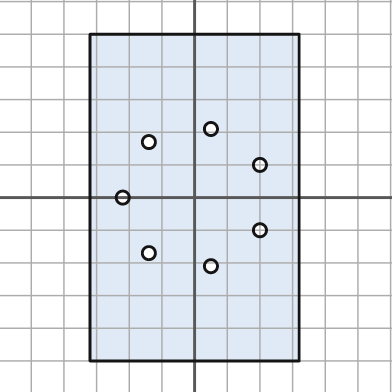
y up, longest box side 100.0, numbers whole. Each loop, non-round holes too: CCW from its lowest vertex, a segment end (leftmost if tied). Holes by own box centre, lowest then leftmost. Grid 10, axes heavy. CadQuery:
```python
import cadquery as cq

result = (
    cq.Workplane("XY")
    .moveTo(-32.0, -50.0)
    .lineTo(32.0, -50.0)
    .lineTo(32.0, 50.0)
    .lineTo(-32.0, 50.0)
    .close()
    .moveTo(5.0, -21.0)
    .circle(2.0)
    .moveTo(-14.0, -17.0)
    .circle(2.0)
    .moveTo(20.0, -10.0)
    .circle(2.0)
    .moveTo(-22.0, 0.0)
    .circle(2.0)
    .moveTo(20.0, 10.0)
    .circle(2.0)
    .moveTo(-14.0, 17.0)
    .circle(2.0)
    .moveTo(5.0, 21.0)
    .circle(2.0)
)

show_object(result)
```